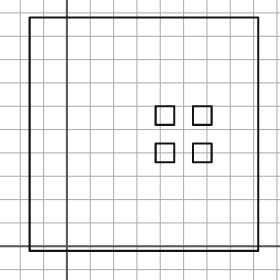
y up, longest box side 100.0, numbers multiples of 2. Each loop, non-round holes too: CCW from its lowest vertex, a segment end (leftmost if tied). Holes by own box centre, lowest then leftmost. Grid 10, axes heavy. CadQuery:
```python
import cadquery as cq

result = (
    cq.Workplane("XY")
    .moveTo(-16.0, -2.0)
    .lineTo(82.0, -2.0)
    .lineTo(82.0, 98.0)
    .lineTo(-16.0, 98.0)
    .close()
    .moveTo(38.0, 36.0)
    .lineTo(46.0, 36.0)
    .lineTo(46.0, 44.0)
    .lineTo(38.0, 44.0)
    .close()
    .moveTo(54.0, 36.0)
    .lineTo(62.0, 36.0)
    .lineTo(62.0, 44.0)
    .lineTo(54.0, 44.0)
    .close()
    .moveTo(38.0, 52.0)
    .lineTo(46.0, 52.0)
    .lineTo(46.0, 60.0)
    .lineTo(38.0, 60.0)
    .close()
    .moveTo(54.0, 52.0)
    .lineTo(62.0, 52.0)
    .lineTo(62.0, 60.0)
    .lineTo(54.0, 60.0)
    .close()
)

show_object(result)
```